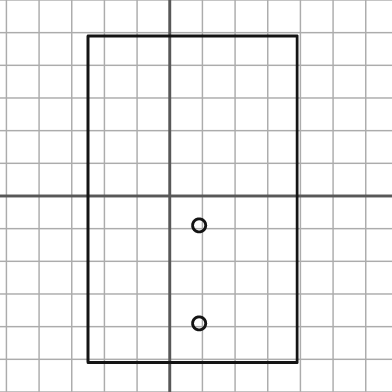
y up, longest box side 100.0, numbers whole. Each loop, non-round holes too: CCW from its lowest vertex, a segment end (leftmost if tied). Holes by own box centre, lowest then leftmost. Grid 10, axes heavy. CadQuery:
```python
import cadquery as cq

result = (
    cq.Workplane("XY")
    .moveTo(-25.0, -51.0)
    .lineTo(39.0, -51.0)
    .lineTo(39.0, 49.0)
    .lineTo(-25.0, 49.0)
    .close()
    .moveTo(9.0, -39.0)
    .circle(2.0)
    .moveTo(9.0, -9.0)
    .circle(2.0)
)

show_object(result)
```